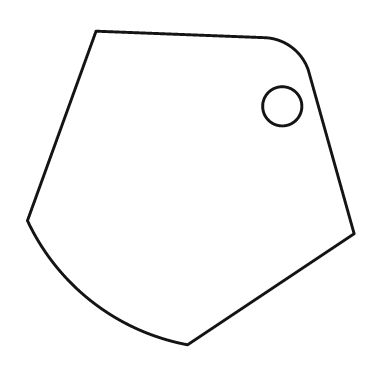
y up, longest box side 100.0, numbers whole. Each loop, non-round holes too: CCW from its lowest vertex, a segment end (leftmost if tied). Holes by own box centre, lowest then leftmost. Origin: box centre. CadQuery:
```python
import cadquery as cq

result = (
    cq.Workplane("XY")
    .moveTo(-1.0, -48.0)
    .lineTo(50.0, -14.0)
    .lineTo(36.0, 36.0)
    .threePointArc((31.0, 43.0), (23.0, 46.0))
    .lineTo(-29.0, 48.0)
    .lineTo(-50.0, -10.0)
    .threePointArc((-30.0, -35.0), (-1.0, -48.0))
    .close()
    .moveTo(28.0, 25.0)
    .circle(6.0)
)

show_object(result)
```